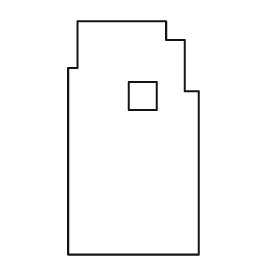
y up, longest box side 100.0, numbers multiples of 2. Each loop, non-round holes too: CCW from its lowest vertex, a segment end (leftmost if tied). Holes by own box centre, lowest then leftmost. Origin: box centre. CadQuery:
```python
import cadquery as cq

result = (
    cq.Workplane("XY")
    .moveTo(-28.0, -50.0)
    .lineTo(28.0, -50.0)
    .lineTo(28.0, 20.0)
    .lineTo(22.0, 20.0)
    .lineTo(22.0, 42.0)
    .lineTo(14.0, 42.0)
    .lineTo(14.0, 50.0)
    .lineTo(-24.0, 50.0)
    .lineTo(-24.0, 30.0)
    .lineTo(-28.0, 30.0)
    .close()
    .moveTo(-2.0, 12.0)
    .lineTo(10.0, 12.0)
    .lineTo(10.0, 24.0)
    .lineTo(-2.0, 24.0)
    .close()
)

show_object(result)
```